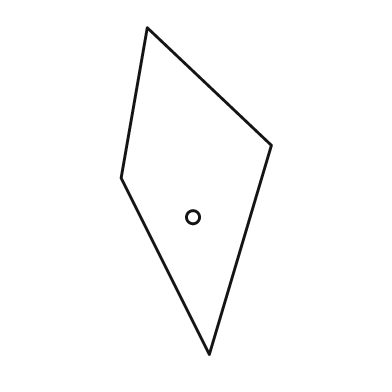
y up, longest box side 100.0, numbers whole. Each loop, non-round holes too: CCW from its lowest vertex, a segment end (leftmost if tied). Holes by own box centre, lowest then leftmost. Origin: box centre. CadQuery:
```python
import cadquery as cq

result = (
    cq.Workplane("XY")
    .moveTo(4.0, -50.0)
    .lineTo(23.0, 14.0)
    .lineTo(-15.0, 50.0)
    .lineTo(-23.0, 4.0)
    .close()
    .moveTo(-1.0, -8.0)
    .circle(2.0)
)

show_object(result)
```